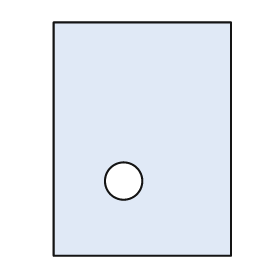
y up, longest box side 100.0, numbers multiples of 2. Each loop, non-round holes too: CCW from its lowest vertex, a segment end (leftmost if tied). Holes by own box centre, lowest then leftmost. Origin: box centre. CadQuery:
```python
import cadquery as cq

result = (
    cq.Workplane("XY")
    .moveTo(-38.0, -50.0)
    .lineTo(38.0, -50.0)
    .lineTo(38.0, 50.0)
    .lineTo(-38.0, 50.0)
    .close()
    .moveTo(-8.0, -18.0)
    .circle(8.0)
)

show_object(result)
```